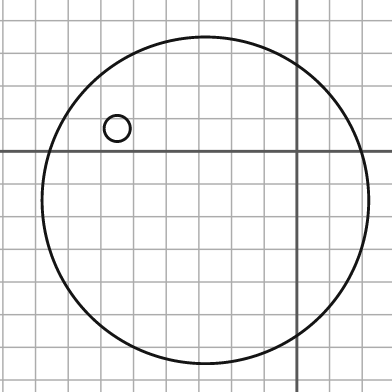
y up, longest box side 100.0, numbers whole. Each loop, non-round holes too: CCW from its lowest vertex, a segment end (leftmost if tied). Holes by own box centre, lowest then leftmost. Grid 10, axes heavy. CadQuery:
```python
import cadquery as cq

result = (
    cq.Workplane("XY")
    .moveTo(-28.0, -15.0)
    .circle(50.0)
    .moveTo(-55.0, 7.0)
    .circle(4.0)
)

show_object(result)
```